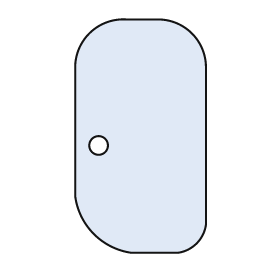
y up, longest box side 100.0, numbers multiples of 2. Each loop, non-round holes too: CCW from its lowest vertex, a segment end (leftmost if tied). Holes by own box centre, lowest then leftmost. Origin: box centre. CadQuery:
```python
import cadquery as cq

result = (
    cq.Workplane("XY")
    .moveTo(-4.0, -50.0)
    .lineTo(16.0, -50.0)
    .threePointArc((24.0, -46.0), (28.0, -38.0))
    .lineTo(28.0, 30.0)
    .threePointArc((22.0, 44.0), (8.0, 50.0))
    .lineTo(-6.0, 50.0)
    .threePointArc((-22.0, 44.0), (-28.0, 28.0))
    .lineTo(-28.0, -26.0)
    .threePointArc((-20.0, -42.0), (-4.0, -50.0))
    .close()
    .moveTo(-18.0, -4.0)
    .circle(4.0)
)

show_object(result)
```